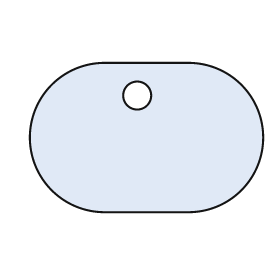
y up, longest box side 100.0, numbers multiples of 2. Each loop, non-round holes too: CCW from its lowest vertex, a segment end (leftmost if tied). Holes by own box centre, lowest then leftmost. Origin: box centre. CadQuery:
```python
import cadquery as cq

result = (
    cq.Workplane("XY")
    .moveTo(-18.0, -32.0)
    .lineTo(18.0, -32.0)
    .threePointArc((50.0, 0.0), (18.0, 32.0))
    .lineTo(-18.0, 32.0)
    .threePointArc((-50.0, 0.0), (-18.0, -32.0))
    .close()
    .moveTo(-4.0, 18.0)
    .circle(6.0)
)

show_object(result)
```